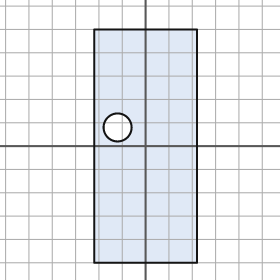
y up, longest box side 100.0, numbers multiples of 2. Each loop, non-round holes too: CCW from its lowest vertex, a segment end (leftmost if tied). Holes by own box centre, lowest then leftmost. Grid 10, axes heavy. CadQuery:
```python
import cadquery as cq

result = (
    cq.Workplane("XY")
    .moveTo(-22.0, -50.0)
    .lineTo(22.0, -50.0)
    .lineTo(22.0, 50.0)
    .lineTo(-22.0, 50.0)
    .close()
    .moveTo(-12.0, 8.0)
    .circle(6.0)
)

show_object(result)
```